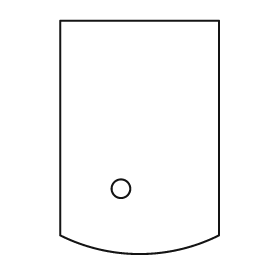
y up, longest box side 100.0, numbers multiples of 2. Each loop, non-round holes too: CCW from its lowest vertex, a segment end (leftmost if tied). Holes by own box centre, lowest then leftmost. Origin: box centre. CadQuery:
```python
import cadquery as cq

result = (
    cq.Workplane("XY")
    .moveTo(-34.0, -42.0)
    .threePointArc((0.0, -50.0), (34.0, -42.0))
    .lineTo(34.0, 50.0)
    .lineTo(-34.0, 50.0)
    .close()
    .moveTo(-8.0, -22.0)
    .circle(4.0)
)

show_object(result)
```